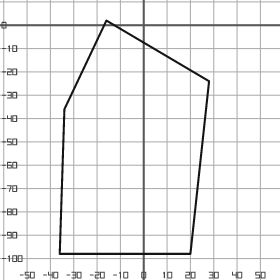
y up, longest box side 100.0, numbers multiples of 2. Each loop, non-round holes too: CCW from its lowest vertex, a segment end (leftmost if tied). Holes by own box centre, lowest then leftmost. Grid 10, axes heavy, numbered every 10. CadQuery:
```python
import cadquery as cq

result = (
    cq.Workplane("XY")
    .moveTo(-36.0, -98.0)
    .lineTo(20.0, -98.0)
    .lineTo(28.0, -24.0)
    .lineTo(-16.0, 2.0)
    .lineTo(-34.0, -36.0)
    .close()
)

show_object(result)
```